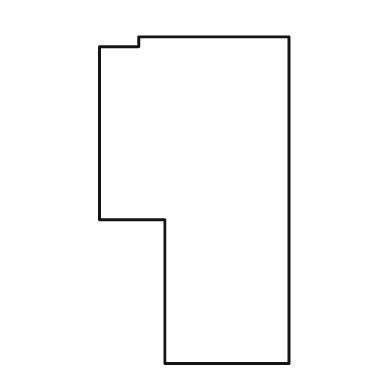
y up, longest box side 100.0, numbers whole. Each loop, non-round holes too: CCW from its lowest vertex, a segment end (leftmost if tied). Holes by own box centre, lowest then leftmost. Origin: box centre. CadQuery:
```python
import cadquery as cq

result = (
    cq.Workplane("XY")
    .moveTo(-9.0, -50.0)
    .lineTo(29.0, -50.0)
    .lineTo(29.0, 50.0)
    .lineTo(-17.0, 50.0)
    .lineTo(-17.0, 47.0)
    .lineTo(-29.0, 47.0)
    .lineTo(-29.0, -6.0)
    .lineTo(-9.0, -6.0)
    .close()
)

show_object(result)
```